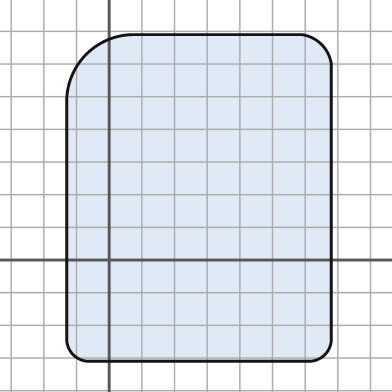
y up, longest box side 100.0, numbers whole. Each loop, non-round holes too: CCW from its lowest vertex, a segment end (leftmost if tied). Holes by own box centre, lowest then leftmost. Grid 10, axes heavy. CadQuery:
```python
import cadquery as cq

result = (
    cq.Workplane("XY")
    .moveTo(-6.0, -31.0)
    .lineTo(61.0, -31.0)
    .threePointArc((66.0, -29.0), (68.0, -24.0))
    .lineTo(68.0, 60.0)
    .threePointArc((65.0, 66.0), (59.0, 69.0))
    .lineTo(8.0, 69.0)
    .threePointArc((-7.0, 63.0), (-13.0, 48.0))
    .lineTo(-13.0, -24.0)
    .threePointArc((-11.0, -29.0), (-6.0, -31.0))
    .close()
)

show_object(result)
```